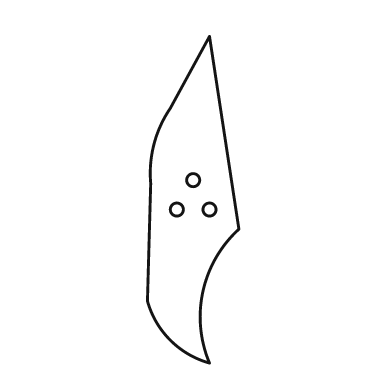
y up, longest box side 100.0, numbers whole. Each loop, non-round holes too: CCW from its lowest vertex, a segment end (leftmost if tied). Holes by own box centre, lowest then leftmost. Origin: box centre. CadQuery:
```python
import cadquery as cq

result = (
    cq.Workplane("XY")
    .moveTo(5.0, -50.0)
    .threePointArc((3.0, -28.0), (14.0, -9.0))
    .lineTo(5.0, 50.0)
    .lineTo(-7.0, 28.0)
    .threePointArc((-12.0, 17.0), (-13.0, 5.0))
    .lineTo(-14.0, -31.0)
    .threePointArc((-7.0, -43.0), (5.0, -50.0))
    .close()
    .moveTo(-5.0, -3.0)
    .circle(2.0)
    .moveTo(5.0, -3.0)
    .circle(2.0)
    .moveTo(0.0, 6.0)
    .circle(2.0)
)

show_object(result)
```